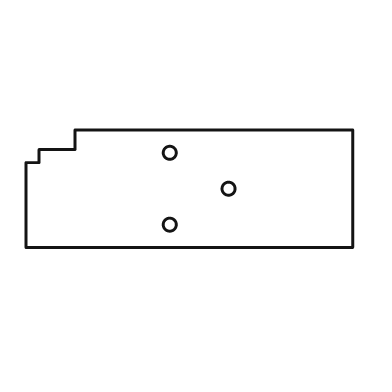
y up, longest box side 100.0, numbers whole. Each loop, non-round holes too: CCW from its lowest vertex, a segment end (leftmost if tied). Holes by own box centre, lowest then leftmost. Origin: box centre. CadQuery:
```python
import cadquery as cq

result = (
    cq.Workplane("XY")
    .moveTo(-50.0, -18.0)
    .lineTo(50.0, -18.0)
    .lineTo(50.0, 18.0)
    .lineTo(-35.0, 18.0)
    .lineTo(-35.0, 12.0)
    .lineTo(-46.0, 12.0)
    .lineTo(-46.0, 8.0)
    .lineTo(-50.0, 8.0)
    .close()
    .moveTo(-6.0, -11.0)
    .circle(2.0)
    .moveTo(12.0, 0.0)
    .circle(2.0)
    .moveTo(-6.0, 11.0)
    .circle(2.0)
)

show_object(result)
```